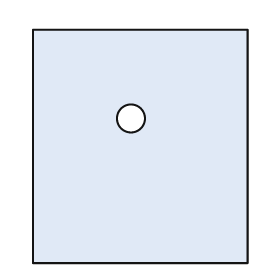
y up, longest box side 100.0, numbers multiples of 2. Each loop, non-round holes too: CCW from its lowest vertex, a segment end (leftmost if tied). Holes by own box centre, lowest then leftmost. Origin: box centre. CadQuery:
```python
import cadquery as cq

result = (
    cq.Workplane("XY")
    .moveTo(-46.0, -50.0)
    .lineTo(46.0, -50.0)
    .lineTo(46.0, 50.0)
    .lineTo(-46.0, 50.0)
    .close()
    .moveTo(-4.0, 12.0)
    .circle(6.0)
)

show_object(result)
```